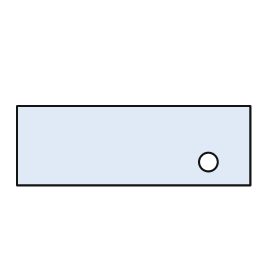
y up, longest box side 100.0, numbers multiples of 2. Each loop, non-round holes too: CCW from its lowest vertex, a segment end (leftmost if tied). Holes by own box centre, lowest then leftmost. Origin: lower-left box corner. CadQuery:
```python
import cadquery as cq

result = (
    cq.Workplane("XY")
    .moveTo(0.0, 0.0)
    .lineTo(100.0, 0.0)
    .lineTo(100.0, 34.0)
    .lineTo(0.0, 34.0)
    .close()
    .moveTo(82.0, 10.0)
    .circle(4.0)
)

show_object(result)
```